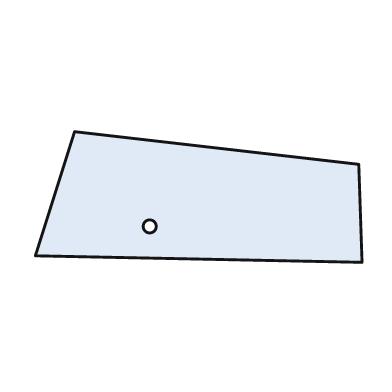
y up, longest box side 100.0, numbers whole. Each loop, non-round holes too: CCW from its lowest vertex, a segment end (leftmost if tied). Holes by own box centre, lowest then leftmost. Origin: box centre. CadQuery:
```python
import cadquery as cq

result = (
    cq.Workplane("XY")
    .moveTo(50.0, -20.0)
    .lineTo(49.0, 10.0)
    .lineTo(-38.0, 20.0)
    .lineTo(-50.0, -18.0)
    .close()
    .moveTo(-15.0, -9.0)
    .circle(2.0)
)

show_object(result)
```